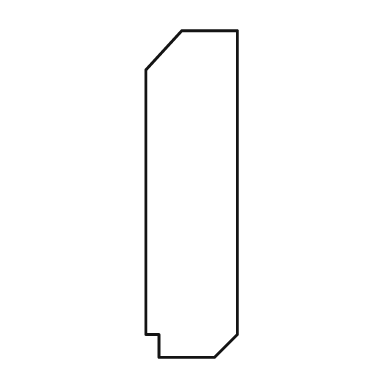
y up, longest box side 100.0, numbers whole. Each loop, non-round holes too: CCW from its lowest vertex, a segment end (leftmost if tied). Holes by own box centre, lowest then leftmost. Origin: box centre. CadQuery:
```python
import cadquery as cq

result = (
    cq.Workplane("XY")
    .moveTo(-10.0, -50.0)
    .lineTo(7.0, -50.0)
    .lineTo(14.0, -43.0)
    .lineTo(14.0, 50.0)
    .lineTo(-3.0, 50.0)
    .lineTo(-14.0, 38.0)
    .lineTo(-14.0, -43.0)
    .lineTo(-10.0, -43.0)
    .close()
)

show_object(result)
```